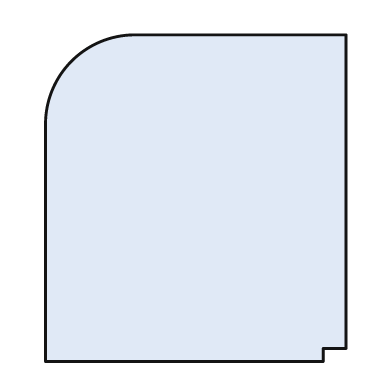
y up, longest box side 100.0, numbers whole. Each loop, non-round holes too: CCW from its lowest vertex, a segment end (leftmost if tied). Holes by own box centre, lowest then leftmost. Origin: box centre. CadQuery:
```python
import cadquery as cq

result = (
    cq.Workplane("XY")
    .moveTo(-46.0, -50.0)
    .lineTo(39.0, -50.0)
    .lineTo(39.0, -46.0)
    .lineTo(46.0, -46.0)
    .lineTo(46.0, 50.0)
    .lineTo(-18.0, 50.0)
    .threePointArc((-38.0, 42.0), (-46.0, 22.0))
    .close()
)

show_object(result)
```